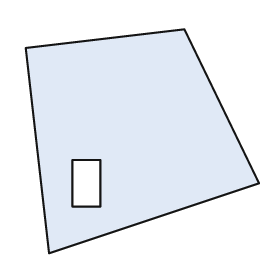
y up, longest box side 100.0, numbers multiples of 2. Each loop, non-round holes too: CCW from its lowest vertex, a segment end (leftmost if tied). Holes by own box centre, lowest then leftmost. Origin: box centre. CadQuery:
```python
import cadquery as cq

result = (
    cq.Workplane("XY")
    .moveTo(-40.0, -48.0)
    .lineTo(50.0, -18.0)
    .lineTo(18.0, 48.0)
    .lineTo(-50.0, 40.0)
    .close()
    .moveTo(-30.0, -28.0)
    .lineTo(-18.0, -28.0)
    .lineTo(-18.0, -8.0)
    .lineTo(-30.0, -8.0)
    .close()
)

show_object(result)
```